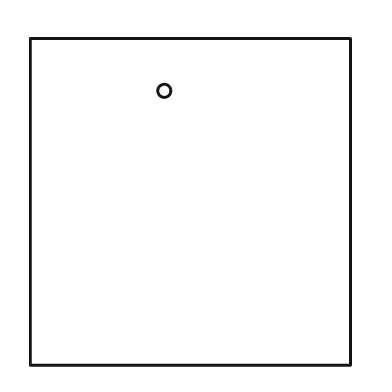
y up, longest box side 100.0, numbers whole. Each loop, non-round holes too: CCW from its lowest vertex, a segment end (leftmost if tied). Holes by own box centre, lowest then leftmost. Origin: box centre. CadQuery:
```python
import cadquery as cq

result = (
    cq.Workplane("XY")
    .moveTo(-49.0, -50.0)
    .lineTo(49.0, -50.0)
    .lineTo(49.0, 50.0)
    .lineTo(-49.0, 50.0)
    .close()
    .moveTo(-8.0, 34.0)
    .circle(2.0)
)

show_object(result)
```